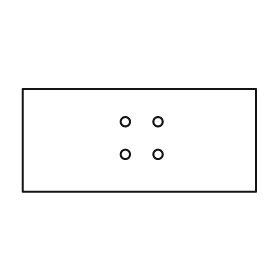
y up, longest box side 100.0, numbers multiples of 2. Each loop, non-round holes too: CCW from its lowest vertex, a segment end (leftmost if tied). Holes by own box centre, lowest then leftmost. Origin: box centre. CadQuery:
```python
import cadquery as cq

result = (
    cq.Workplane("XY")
    .moveTo(-50.0, -22.0)
    .lineTo(50.0, -22.0)
    .lineTo(50.0, 22.0)
    .lineTo(-50.0, 22.0)
    .close()
    .moveTo(-6.0, -6.0)
    .circle(2.0)
    .moveTo(8.0, -6.0)
    .circle(2.0)
    .moveTo(-6.0, 8.0)
    .circle(2.0)
    .moveTo(8.0, 8.0)
    .circle(2.0)
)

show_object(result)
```